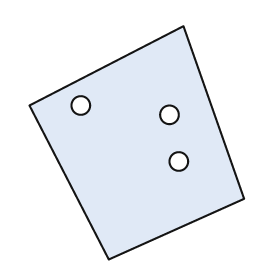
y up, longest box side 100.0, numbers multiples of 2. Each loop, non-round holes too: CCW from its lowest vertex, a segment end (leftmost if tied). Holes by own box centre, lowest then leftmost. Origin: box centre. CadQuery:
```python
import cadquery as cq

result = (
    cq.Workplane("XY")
    .moveTo(-12.0, -50.0)
    .lineTo(46.0, -24.0)
    .lineTo(20.0, 50.0)
    .lineTo(-46.0, 16.0)
    .close()
    .moveTo(18.0, -8.0)
    .circle(4.0)
    .moveTo(14.0, 12.0)
    .circle(4.0)
    .moveTo(-24.0, 16.0)
    .circle(4.0)
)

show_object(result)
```